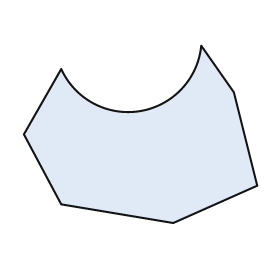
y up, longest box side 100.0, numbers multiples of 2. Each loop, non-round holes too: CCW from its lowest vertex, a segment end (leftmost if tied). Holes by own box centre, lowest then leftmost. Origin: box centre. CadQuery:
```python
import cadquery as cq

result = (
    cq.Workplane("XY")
    .moveTo(14.0, -38.0)
    .lineTo(50.0, -22.0)
    .lineTo(40.0, 18.0)
    .lineTo(26.0, 38.0)
    .threePointArc((0.0, 10.0), (-34.0, 28.0))
    .lineTo(-50.0, 0.0)
    .lineTo(-34.0, -30.0)
    .close()
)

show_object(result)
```